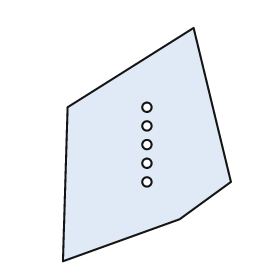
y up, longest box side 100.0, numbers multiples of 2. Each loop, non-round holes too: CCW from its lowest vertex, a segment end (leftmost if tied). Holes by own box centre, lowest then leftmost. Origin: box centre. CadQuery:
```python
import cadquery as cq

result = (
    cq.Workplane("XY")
    .moveTo(-36.0, -50.0)
    .lineTo(14.0, -32.0)
    .lineTo(36.0, -16.0)
    .lineTo(20.0, 50.0)
    .lineTo(-34.0, 16.0)
    .close()
    .moveTo(0.0, -16.0)
    .circle(2.0)
    .moveTo(0.0, -8.0)
    .circle(2.0)
    .moveTo(0.0, 0.0)
    .circle(2.0)
    .moveTo(0.0, 8.0)
    .circle(2.0)
    .moveTo(0.0, 16.0)
    .circle(2.0)
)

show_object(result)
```